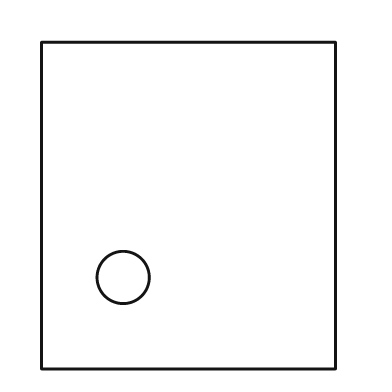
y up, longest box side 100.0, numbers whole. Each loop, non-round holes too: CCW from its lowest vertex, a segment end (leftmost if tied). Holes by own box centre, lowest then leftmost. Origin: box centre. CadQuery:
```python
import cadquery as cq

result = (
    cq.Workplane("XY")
    .moveTo(-45.0, -50.0)
    .lineTo(45.0, -50.0)
    .lineTo(45.0, 50.0)
    .lineTo(-45.0, 50.0)
    .close()
    .moveTo(-20.0, -22.0)
    .circle(8.0)
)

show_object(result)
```